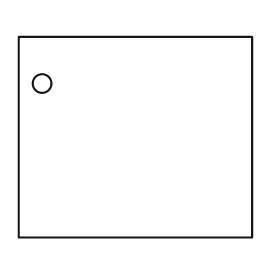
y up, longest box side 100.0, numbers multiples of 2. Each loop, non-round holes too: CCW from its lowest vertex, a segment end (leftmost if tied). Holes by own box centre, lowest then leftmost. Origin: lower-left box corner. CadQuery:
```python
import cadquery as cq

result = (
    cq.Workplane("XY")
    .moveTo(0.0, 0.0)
    .lineTo(100.0, 0.0)
    .lineTo(100.0, 86.0)
    .lineTo(0.0, 86.0)
    .close()
    .moveTo(10.0, 66.0)
    .circle(4.0)
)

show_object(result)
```